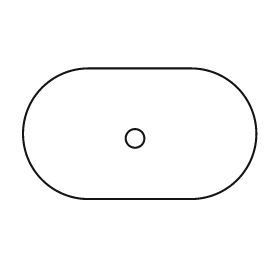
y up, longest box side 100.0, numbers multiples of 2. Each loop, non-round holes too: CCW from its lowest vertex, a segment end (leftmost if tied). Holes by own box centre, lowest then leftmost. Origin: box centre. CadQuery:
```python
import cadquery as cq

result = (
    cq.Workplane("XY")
    .moveTo(-22.0, -28.0)
    .lineTo(22.0, -28.0)
    .threePointArc((50.0, 0.0), (22.0, 28.0))
    .lineTo(-22.0, 28.0)
    .threePointArc((-50.0, 0.0), (-22.0, -28.0))
    .close()
    .moveTo(-2.0, -2.0)
    .circle(4.0)
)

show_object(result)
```